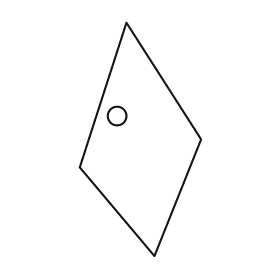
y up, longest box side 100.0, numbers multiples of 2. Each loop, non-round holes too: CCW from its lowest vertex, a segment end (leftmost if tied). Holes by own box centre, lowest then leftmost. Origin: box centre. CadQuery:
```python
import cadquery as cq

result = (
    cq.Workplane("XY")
    .moveTo(6.0, -50.0)
    .lineTo(26.0, 0.0)
    .lineTo(-6.0, 50.0)
    .lineTo(-26.0, -12.0)
    .close()
    .moveTo(-10.0, 10.0)
    .circle(4.0)
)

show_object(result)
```